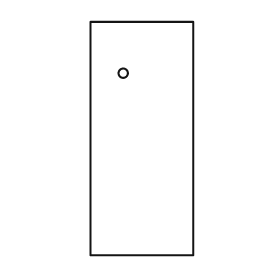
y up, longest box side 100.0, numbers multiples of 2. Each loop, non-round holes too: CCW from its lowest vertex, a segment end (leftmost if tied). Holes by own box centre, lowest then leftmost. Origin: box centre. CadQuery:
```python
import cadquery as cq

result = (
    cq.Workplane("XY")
    .moveTo(-22.0, -50.0)
    .lineTo(22.0, -50.0)
    .lineTo(22.0, 50.0)
    .lineTo(-22.0, 50.0)
    .close()
    .moveTo(-8.0, 28.0)
    .circle(2.0)
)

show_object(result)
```